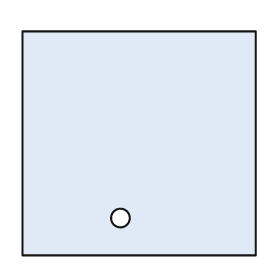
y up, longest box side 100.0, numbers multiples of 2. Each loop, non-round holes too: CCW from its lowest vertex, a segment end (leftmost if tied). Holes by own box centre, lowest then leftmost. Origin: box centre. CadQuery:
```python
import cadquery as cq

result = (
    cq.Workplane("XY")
    .moveTo(-50.0, -48.0)
    .lineTo(50.0, -48.0)
    .lineTo(50.0, 48.0)
    .lineTo(-50.0, 48.0)
    .close()
    .moveTo(-8.0, -32.0)
    .circle(4.0)
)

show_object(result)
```